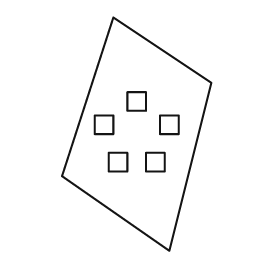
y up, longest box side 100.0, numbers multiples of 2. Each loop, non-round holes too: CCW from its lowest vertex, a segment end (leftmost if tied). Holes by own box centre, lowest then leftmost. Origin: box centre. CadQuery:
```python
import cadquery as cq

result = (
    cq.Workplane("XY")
    .moveTo(14.0, -50.0)
    .lineTo(32.0, 22.0)
    .lineTo(-10.0, 50.0)
    .lineTo(-32.0, -18.0)
    .close()
    .moveTo(-12.0, -16.0)
    .lineTo(-4.0, -16.0)
    .lineTo(-4.0, -8.0)
    .lineTo(-12.0, -8.0)
    .close()
    .moveTo(4.0, -16.0)
    .lineTo(12.0, -16.0)
    .lineTo(12.0, -8.0)
    .lineTo(4.0, -8.0)
    .close()
    .moveTo(-18.0, 0.0)
    .lineTo(-10.0, 0.0)
    .lineTo(-10.0, 8.0)
    .lineTo(-18.0, 8.0)
    .close()
    .moveTo(10.0, 0.0)
    .lineTo(18.0, 0.0)
    .lineTo(18.0, 8.0)
    .lineTo(10.0, 8.0)
    .close()
    .moveTo(-4.0, 10.0)
    .lineTo(4.0, 10.0)
    .lineTo(4.0, 18.0)
    .lineTo(-4.0, 18.0)
    .close()
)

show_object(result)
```